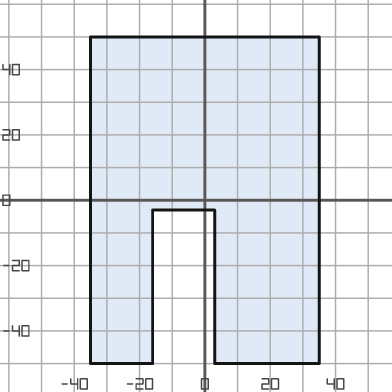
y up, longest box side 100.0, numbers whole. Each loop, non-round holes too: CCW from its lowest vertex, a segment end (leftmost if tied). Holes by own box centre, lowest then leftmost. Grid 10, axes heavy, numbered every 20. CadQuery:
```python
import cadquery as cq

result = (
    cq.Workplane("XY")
    .moveTo(-35.0, -50.0)
    .lineTo(-16.0, -50.0)
    .lineTo(-16.0, -3.0)
    .lineTo(3.0, -3.0)
    .lineTo(3.0, -50.0)
    .lineTo(35.0, -50.0)
    .lineTo(35.0, 50.0)
    .lineTo(-35.0, 50.0)
    .close()
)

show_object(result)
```